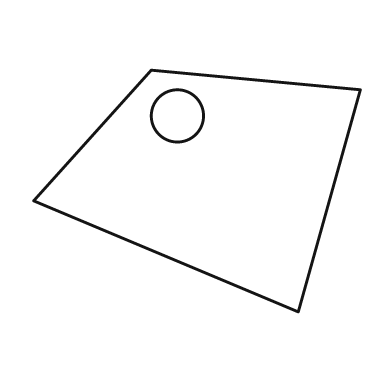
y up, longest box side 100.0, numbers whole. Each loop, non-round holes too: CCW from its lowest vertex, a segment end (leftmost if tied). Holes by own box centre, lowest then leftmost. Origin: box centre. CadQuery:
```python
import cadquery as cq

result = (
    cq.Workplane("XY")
    .moveTo(31.0, -37.0)
    .lineTo(50.0, 31.0)
    .lineTo(-14.0, 37.0)
    .lineTo(-50.0, -3.0)
    .close()
    .moveTo(-6.0, 23.0)
    .circle(8.0)
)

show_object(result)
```